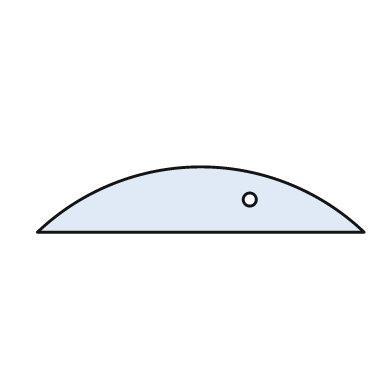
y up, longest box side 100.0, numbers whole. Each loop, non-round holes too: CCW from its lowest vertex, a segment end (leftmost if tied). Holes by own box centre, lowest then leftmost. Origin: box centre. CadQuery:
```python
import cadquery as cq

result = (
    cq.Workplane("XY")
    .moveTo(-50.0, -10.0)
    .lineTo(50.0, -10.0)
    .threePointArc((0.0, 10.0), (-50.0, -10.0))
    .close()
    .moveTo(15.0, 0.0)
    .circle(2.0)
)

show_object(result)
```